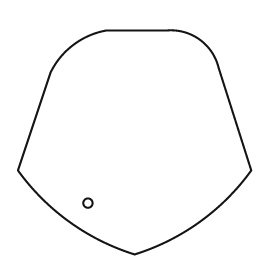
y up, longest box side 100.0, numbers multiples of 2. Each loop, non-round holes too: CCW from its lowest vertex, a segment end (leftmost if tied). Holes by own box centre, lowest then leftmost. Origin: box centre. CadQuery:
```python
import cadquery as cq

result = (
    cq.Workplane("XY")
    .moveTo(0.0, -48.0)
    .threePointArc((28.0, -34.0), (50.0, -12.0))
    .lineTo(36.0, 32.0)
    .threePointArc((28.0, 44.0), (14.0, 48.0))
    .lineTo(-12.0, 48.0)
    .threePointArc((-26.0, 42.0), (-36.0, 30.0))
    .lineTo(-50.0, -12.0)
    .threePointArc((-28.0, -34.0), (0.0, -48.0))
    .close()
    .moveTo(-20.0, -26.0)
    .circle(2.0)
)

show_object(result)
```